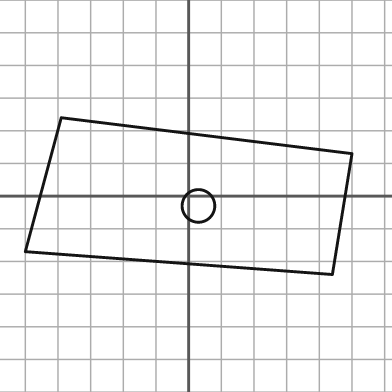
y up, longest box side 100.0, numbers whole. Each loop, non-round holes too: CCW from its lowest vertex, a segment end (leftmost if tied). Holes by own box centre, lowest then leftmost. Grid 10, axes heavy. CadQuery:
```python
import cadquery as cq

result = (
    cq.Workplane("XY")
    .moveTo(44.0, -24.0)
    .lineTo(50.0, 13.0)
    .lineTo(-39.0, 24.0)
    .lineTo(-50.0, -17.0)
    .close()
    .moveTo(3.0, -3.0)
    .circle(5.0)
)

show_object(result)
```